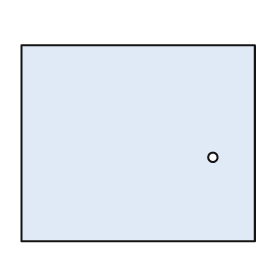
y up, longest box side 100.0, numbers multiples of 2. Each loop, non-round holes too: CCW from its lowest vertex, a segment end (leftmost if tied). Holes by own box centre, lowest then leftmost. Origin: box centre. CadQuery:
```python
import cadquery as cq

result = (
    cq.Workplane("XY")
    .moveTo(-50.0, -42.0)
    .lineTo(50.0, -42.0)
    .lineTo(50.0, 42.0)
    .lineTo(-50.0, 42.0)
    .close()
    .moveTo(32.0, -6.0)
    .circle(2.0)
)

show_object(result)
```